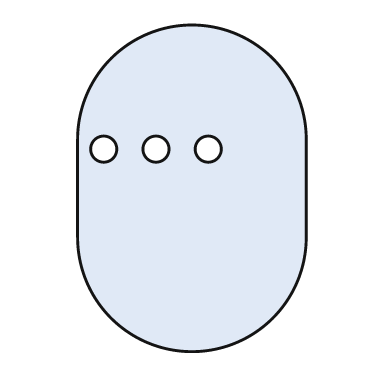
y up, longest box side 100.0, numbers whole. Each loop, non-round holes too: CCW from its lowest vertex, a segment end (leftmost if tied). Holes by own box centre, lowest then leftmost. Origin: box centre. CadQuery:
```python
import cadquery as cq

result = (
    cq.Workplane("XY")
    .moveTo(-35.0, -15.0)
    .threePointArc((0.0, -50.0), (35.0, -15.0))
    .lineTo(35.0, 15.0)
    .threePointArc((0.0, 50.0), (-35.0, 15.0))
    .close()
    .moveTo(-27.0, 12.0)
    .circle(4.0)
    .moveTo(-11.0, 12.0)
    .circle(4.0)
    .moveTo(5.0, 12.0)
    .circle(4.0)
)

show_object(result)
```